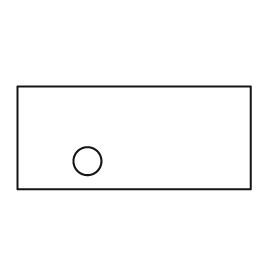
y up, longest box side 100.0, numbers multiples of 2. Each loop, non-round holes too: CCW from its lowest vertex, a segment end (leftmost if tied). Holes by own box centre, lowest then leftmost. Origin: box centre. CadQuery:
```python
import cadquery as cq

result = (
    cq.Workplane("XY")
    .moveTo(-50.0, -22.0)
    .lineTo(50.0, -22.0)
    .lineTo(50.0, 22.0)
    .lineTo(-50.0, 22.0)
    .close()
    .moveTo(-20.0, -10.0)
    .circle(6.0)
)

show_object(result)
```